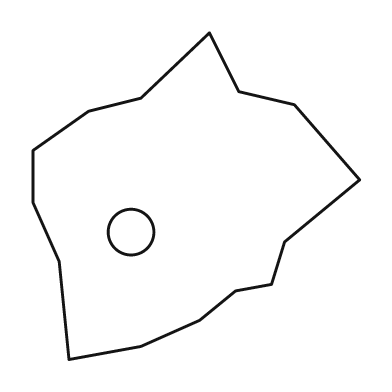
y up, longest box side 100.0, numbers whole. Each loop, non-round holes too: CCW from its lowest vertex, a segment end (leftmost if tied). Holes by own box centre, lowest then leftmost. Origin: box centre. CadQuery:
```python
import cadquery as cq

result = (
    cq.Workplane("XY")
    .moveTo(-39.0, -50.0)
    .lineTo(-17.0, -46.0)
    .lineTo(1.0, -38.0)
    .lineTo(12.0, -29.0)
    .lineTo(23.0, -27.0)
    .lineTo(27.0, -14.0)
    .lineTo(50.0, 5.0)
    .lineTo(30.0, 28.0)
    .lineTo(13.0, 32.0)
    .lineTo(4.0, 50.0)
    .lineTo(-17.0, 30.0)
    .lineTo(-33.0, 26.0)
    .lineTo(-50.0, 14.0)
    .lineTo(-50.0, -2.0)
    .lineTo(-42.0, -20.0)
    .close()
    .moveTo(-20.0, -11.0)
    .circle(7.0)
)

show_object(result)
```